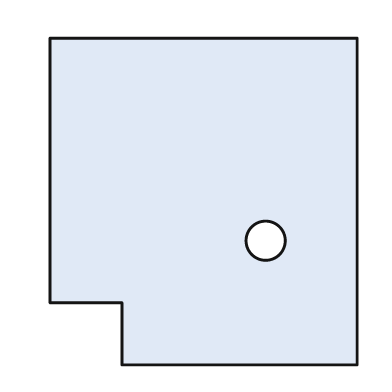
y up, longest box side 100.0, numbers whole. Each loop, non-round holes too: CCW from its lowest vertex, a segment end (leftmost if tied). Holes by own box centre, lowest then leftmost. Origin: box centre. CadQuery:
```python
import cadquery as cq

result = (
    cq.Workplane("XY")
    .moveTo(-25.0, -50.0)
    .lineTo(47.0, -50.0)
    .lineTo(47.0, 50.0)
    .lineTo(-47.0, 50.0)
    .lineTo(-47.0, -31.0)
    .lineTo(-25.0, -31.0)
    .close()
    .moveTo(19.0, -12.0)
    .circle(6.0)
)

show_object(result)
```